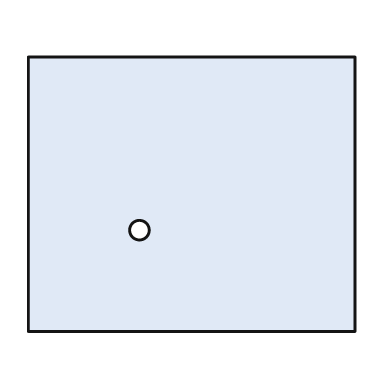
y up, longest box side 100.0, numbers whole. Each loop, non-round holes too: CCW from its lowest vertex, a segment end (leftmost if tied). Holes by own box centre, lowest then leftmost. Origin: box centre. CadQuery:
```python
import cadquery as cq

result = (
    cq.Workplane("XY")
    .moveTo(-50.0, -42.0)
    .lineTo(50.0, -42.0)
    .lineTo(50.0, 42.0)
    .lineTo(-50.0, 42.0)
    .close()
    .moveTo(-16.0, -11.0)
    .circle(3.0)
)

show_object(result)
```